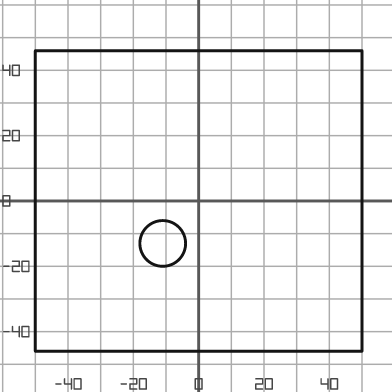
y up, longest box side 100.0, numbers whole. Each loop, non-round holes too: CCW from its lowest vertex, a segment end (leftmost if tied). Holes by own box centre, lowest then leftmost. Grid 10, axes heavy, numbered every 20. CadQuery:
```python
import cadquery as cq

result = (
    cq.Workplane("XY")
    .moveTo(-50.0, -46.0)
    .lineTo(50.0, -46.0)
    .lineTo(50.0, 46.0)
    .lineTo(-50.0, 46.0)
    .close()
    .moveTo(-11.0, -13.0)
    .circle(7.0)
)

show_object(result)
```